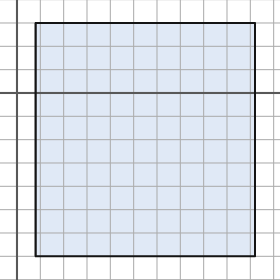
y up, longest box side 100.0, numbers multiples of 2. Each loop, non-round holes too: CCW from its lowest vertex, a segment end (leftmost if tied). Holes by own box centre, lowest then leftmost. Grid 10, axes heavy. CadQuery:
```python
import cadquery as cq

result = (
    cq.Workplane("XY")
    .moveTo(8.0, -70.0)
    .lineTo(102.0, -70.0)
    .lineTo(102.0, 30.0)
    .lineTo(8.0, 30.0)
    .close()
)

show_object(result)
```